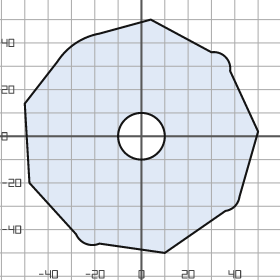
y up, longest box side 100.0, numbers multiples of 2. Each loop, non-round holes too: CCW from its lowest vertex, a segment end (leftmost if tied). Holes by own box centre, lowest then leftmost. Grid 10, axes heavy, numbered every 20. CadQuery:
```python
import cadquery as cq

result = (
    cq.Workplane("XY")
    .moveTo(10.0, -50.0)
    .lineTo(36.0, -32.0)
    .threePointArc((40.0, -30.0), (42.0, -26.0))
    .lineTo(50.0, 2.0)
    .lineTo(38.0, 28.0)
    .threePointArc((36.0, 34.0), (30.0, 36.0))
    .lineTo(4.0, 50.0)
    .lineTo(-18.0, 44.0)
    .threePointArc((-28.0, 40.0), (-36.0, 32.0))
    .lineTo(-50.0, 14.0)
    .lineTo(-48.0, -20.0)
    .lineTo(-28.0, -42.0)
    .threePointArc((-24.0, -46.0), (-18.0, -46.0))
    .close()
    .moveTo(0.0, 0.0)
    .circle(10.0)
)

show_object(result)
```